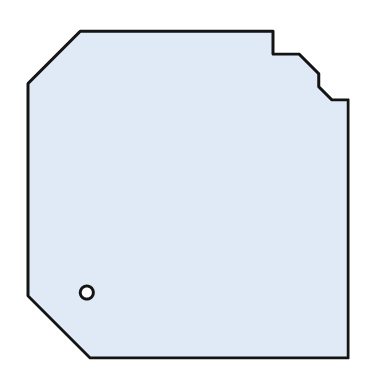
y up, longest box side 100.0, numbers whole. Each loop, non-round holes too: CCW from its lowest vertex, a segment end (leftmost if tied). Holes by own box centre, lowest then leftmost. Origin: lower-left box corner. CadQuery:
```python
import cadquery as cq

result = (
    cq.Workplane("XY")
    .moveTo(19.0, 0.0)
    .lineTo(98.0, 0.0)
    .lineTo(98.0, 79.0)
    .lineTo(93.0, 79.0)
    .lineTo(89.0, 83.0)
    .lineTo(89.0, 87.0)
    .lineTo(83.0, 93.0)
    .lineTo(75.0, 93.0)
    .lineTo(75.0, 100.0)
    .lineTo(16.0, 100.0)
    .lineTo(0.0, 84.0)
    .lineTo(0.0, 19.0)
    .close()
    .moveTo(18.0, 20.0)
    .circle(2.0)
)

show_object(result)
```